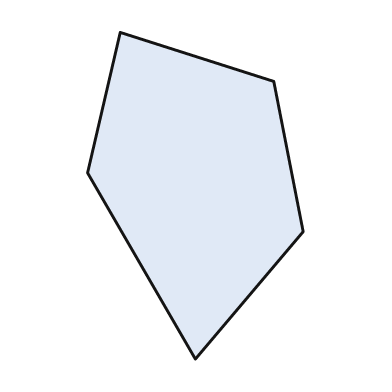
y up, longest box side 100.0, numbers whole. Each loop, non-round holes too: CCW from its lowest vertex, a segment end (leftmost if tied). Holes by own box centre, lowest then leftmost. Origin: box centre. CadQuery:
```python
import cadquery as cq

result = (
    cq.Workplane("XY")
    .moveTo(0.0, -50.0)
    .lineTo(33.0, -11.0)
    .lineTo(24.0, 35.0)
    .lineTo(-23.0, 50.0)
    .lineTo(-33.0, 7.0)
    .close()
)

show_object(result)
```